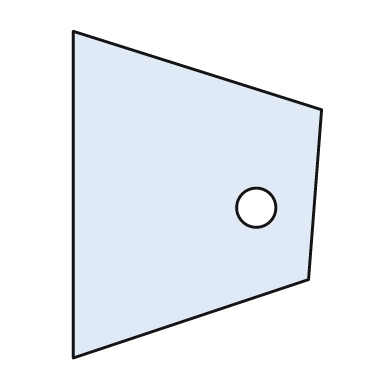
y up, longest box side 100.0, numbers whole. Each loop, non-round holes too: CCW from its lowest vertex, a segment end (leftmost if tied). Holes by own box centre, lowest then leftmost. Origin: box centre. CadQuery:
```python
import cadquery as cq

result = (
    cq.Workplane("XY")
    .moveTo(-38.0, -50.0)
    .lineTo(34.0, -26.0)
    .lineTo(38.0, 26.0)
    .lineTo(-38.0, 50.0)
    .close()
    .moveTo(18.0, -4.0)
    .circle(6.0)
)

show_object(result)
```